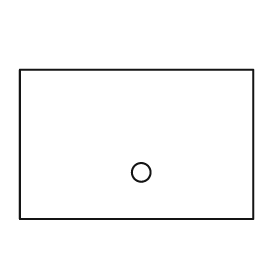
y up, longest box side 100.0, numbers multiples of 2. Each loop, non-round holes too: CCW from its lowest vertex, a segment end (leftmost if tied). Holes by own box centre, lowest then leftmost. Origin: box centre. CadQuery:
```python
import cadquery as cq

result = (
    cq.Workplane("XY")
    .moveTo(-50.0, -32.0)
    .lineTo(50.0, -32.0)
    .lineTo(50.0, 32.0)
    .lineTo(-50.0, 32.0)
    .close()
    .moveTo(2.0, -12.0)
    .circle(4.0)
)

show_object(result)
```